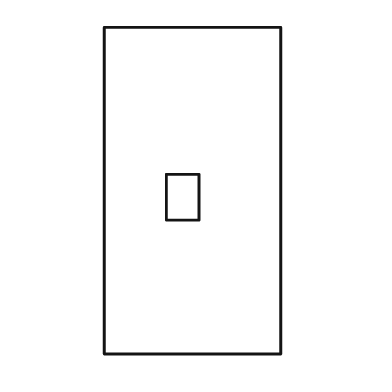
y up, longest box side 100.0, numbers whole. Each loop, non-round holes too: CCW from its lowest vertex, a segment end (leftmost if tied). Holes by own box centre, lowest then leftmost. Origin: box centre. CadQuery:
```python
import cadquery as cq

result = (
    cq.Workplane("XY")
    .moveTo(-27.0, -50.0)
    .lineTo(27.0, -50.0)
    .lineTo(27.0, 50.0)
    .lineTo(-27.0, 50.0)
    .close()
    .moveTo(-8.0, -9.0)
    .lineTo(2.0, -9.0)
    .lineTo(2.0, 5.0)
    .lineTo(-8.0, 5.0)
    .close()
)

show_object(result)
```